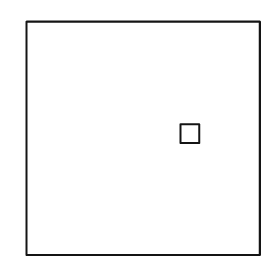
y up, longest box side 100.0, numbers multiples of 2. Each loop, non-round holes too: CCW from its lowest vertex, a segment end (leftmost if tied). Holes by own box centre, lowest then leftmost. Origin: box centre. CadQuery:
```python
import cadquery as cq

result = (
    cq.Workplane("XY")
    .moveTo(-50.0, -50.0)
    .lineTo(50.0, -50.0)
    .lineTo(50.0, 50.0)
    .lineTo(-50.0, 50.0)
    .close()
    .moveTo(16.0, -2.0)
    .lineTo(24.0, -2.0)
    .lineTo(24.0, 6.0)
    .lineTo(16.0, 6.0)
    .close()
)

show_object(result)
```